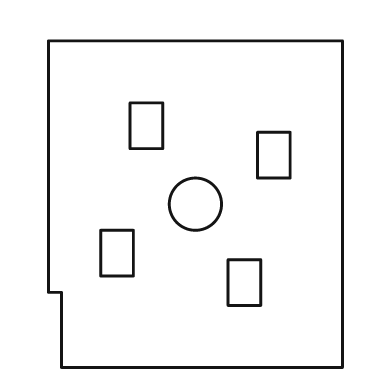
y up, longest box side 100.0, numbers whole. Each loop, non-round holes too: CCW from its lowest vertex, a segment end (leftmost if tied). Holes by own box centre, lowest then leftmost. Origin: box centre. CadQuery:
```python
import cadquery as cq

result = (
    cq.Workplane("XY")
    .moveTo(-41.0, -50.0)
    .lineTo(45.0, -50.0)
    .lineTo(45.0, 50.0)
    .lineTo(-45.0, 50.0)
    .lineTo(-45.0, -27.0)
    .lineTo(-41.0, -27.0)
    .close()
    .moveTo(10.0, -31.0)
    .lineTo(20.0, -31.0)
    .lineTo(20.0, -17.0)
    .lineTo(10.0, -17.0)
    .close()
    .moveTo(-29.0, -22.0)
    .lineTo(-19.0, -22.0)
    .lineTo(-19.0, -8.0)
    .lineTo(-29.0, -8.0)
    .close()
    .moveTo(0.0, 0.0)
    .circle(8.0)
    .moveTo(19.0, 8.0)
    .lineTo(29.0, 8.0)
    .lineTo(29.0, 22.0)
    .lineTo(19.0, 22.0)
    .close()
    .moveTo(-20.0, 17.0)
    .lineTo(-10.0, 17.0)
    .lineTo(-10.0, 31.0)
    .lineTo(-20.0, 31.0)
    .close()
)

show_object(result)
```